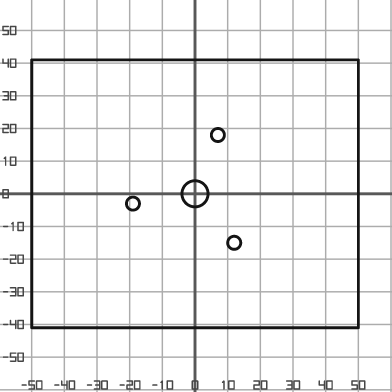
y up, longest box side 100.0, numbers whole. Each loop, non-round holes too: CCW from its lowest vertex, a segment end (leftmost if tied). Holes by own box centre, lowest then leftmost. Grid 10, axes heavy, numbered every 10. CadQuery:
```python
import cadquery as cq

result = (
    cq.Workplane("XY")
    .moveTo(-50.0, -41.0)
    .lineTo(50.0, -41.0)
    .lineTo(50.0, 41.0)
    .lineTo(-50.0, 41.0)
    .close()
    .moveTo(12.0, -15.0)
    .circle(2.0)
    .moveTo(-19.0, -3.0)
    .circle(2.0)
    .moveTo(0.0, 0.0)
    .circle(4.0)
    .moveTo(7.0, 18.0)
    .circle(2.0)
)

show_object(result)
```